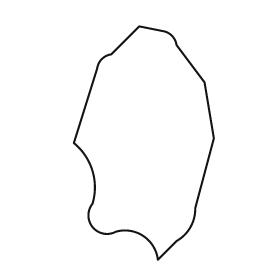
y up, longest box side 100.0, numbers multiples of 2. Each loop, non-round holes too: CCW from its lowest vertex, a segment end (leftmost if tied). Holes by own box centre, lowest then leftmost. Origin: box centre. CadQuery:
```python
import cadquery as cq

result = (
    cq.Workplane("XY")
    .moveTo(6.0, -50.0)
    .lineTo(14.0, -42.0)
    .threePointArc((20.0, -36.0), (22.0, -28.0))
    .lineTo(30.0, 2.0)
    .lineTo(26.0, 26.0)
    .lineTo(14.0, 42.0)
    .threePointArc((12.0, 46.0), (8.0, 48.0))
    .lineTo(-2.0, 50.0)
    .lineTo(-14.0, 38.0)
    .threePointArc((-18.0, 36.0), (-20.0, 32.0))
    .lineTo(-30.0, 0.0)
    .threePointArc((-22.0, -12.0), (-22.0, -26.0))
    .threePointArc((-22.0, -36.0), (-12.0, -38.0))
    .threePointArc((0.0, -40.0), (6.0, -50.0))
    .close()
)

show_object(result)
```